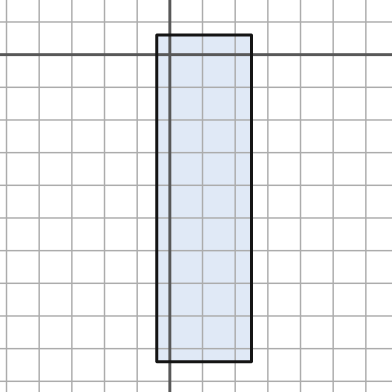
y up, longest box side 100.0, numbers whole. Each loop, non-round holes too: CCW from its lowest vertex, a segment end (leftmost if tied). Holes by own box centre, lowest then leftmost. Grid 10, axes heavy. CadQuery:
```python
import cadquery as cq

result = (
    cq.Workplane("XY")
    .moveTo(-4.0, -94.0)
    .lineTo(25.0, -94.0)
    .lineTo(25.0, 6.0)
    .lineTo(-4.0, 6.0)
    .close()
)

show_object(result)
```